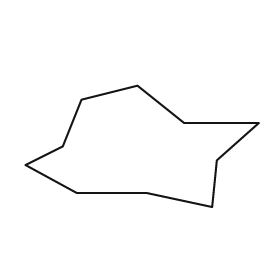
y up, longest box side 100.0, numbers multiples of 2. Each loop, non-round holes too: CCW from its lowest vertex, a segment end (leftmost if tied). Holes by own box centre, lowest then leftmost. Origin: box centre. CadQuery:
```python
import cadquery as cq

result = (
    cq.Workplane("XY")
    .moveTo(30.0, -26.0)
    .lineTo(32.0, -6.0)
    .lineTo(50.0, 10.0)
    .lineTo(18.0, 10.0)
    .lineTo(-2.0, 26.0)
    .lineTo(-26.0, 20.0)
    .lineTo(-34.0, 0.0)
    .lineTo(-50.0, -8.0)
    .lineTo(-28.0, -20.0)
    .lineTo(2.0, -20.0)
    .close()
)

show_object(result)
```